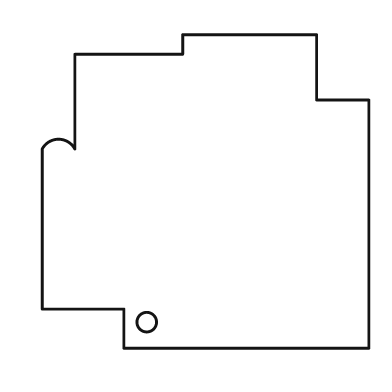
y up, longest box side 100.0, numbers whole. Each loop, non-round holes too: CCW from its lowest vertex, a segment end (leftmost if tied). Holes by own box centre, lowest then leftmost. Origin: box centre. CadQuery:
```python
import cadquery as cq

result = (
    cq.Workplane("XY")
    .moveTo(-25.0, -48.0)
    .lineTo(50.0, -48.0)
    .lineTo(50.0, 28.0)
    .lineTo(34.0, 28.0)
    .lineTo(34.0, 48.0)
    .lineTo(-7.0, 48.0)
    .lineTo(-7.0, 42.0)
    .lineTo(-40.0, 42.0)
    .lineTo(-40.0, 13.0)
    .threePointArc((-45.0, 16.0), (-50.0, 13.0))
    .lineTo(-50.0, -36.0)
    .lineTo(-25.0, -36.0)
    .close()
    .moveTo(-18.0, -40.0)
    .circle(3.0)
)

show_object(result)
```